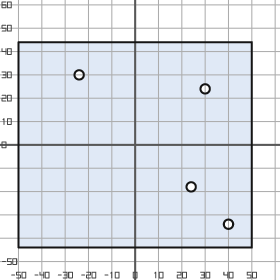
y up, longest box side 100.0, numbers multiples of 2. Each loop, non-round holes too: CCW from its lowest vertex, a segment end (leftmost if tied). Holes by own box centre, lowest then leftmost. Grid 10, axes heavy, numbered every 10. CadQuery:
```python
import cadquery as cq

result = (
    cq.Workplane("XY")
    .moveTo(-50.0, -44.0)
    .lineTo(50.0, -44.0)
    .lineTo(50.0, 44.0)
    .lineTo(-50.0, 44.0)
    .close()
    .moveTo(40.0, -34.0)
    .circle(2.0)
    .moveTo(24.0, -18.0)
    .circle(2.0)
    .moveTo(30.0, 24.0)
    .circle(2.0)
    .moveTo(-24.0, 30.0)
    .circle(2.0)
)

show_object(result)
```